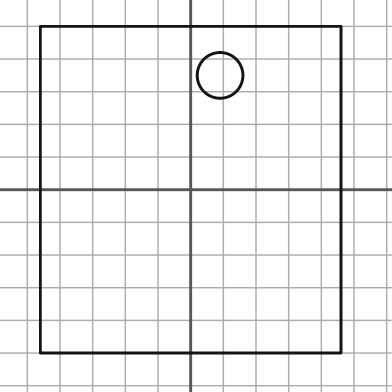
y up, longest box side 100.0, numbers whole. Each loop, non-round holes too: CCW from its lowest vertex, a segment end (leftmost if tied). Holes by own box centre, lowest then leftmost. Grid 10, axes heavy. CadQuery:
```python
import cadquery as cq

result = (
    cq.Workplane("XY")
    .moveTo(-46.0, -50.0)
    .lineTo(46.0, -50.0)
    .lineTo(46.0, 50.0)
    .lineTo(-46.0, 50.0)
    .close()
    .moveTo(9.0, 35.0)
    .circle(7.0)
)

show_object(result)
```